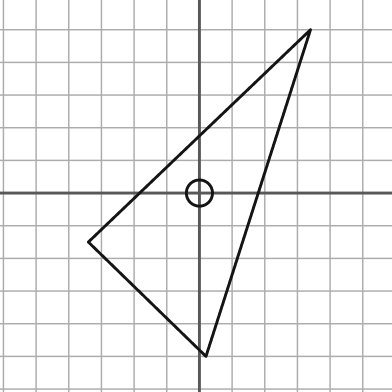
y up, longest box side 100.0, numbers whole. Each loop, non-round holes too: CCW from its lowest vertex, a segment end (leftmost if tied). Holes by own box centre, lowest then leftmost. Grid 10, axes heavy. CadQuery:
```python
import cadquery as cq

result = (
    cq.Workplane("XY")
    .moveTo(2.0, -50.0)
    .lineTo(34.0, 50.0)
    .lineTo(-34.0, -15.0)
    .close()
    .moveTo(0.0, 0.0)
    .circle(4.0)
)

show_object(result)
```